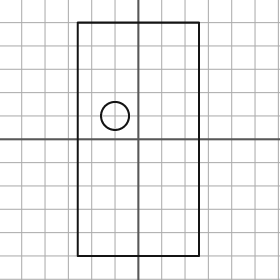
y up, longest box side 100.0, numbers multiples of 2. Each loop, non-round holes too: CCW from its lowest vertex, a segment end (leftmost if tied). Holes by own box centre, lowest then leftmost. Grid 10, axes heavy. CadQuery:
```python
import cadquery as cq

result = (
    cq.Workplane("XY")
    .moveTo(-26.0, -50.0)
    .lineTo(26.0, -50.0)
    .lineTo(26.0, 50.0)
    .lineTo(-26.0, 50.0)
    .close()
    .moveTo(-10.0, 10.0)
    .circle(6.0)
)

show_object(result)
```